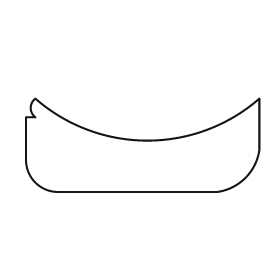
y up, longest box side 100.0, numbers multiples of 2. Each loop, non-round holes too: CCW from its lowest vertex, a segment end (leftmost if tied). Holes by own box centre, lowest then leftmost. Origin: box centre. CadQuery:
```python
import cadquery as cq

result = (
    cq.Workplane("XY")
    .moveTo(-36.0, -20.0)
    .lineTo(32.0, -20.0)
    .threePointArc((44.0, -14.0), (50.0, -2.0))
    .lineTo(50.0, 20.0)
    .threePointArc((2.0, 2.0), (-46.0, 20.0))
    .threePointArc((-48.0, 16.0), (-46.0, 12.0))
    .lineTo(-50.0, 12.0)
    .lineTo(-50.0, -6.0)
    .threePointArc((-46.0, -16.0), (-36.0, -20.0))
    .close()
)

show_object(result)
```